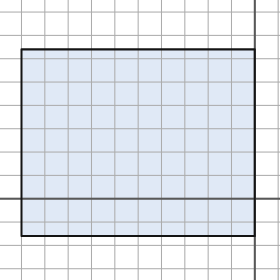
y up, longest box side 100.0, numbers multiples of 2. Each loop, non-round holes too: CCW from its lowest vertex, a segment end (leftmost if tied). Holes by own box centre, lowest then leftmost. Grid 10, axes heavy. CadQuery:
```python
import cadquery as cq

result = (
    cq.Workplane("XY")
    .moveTo(-100.0, -16.0)
    .lineTo(0.0, -16.0)
    .lineTo(0.0, 64.0)
    .lineTo(-100.0, 64.0)
    .close()
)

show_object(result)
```